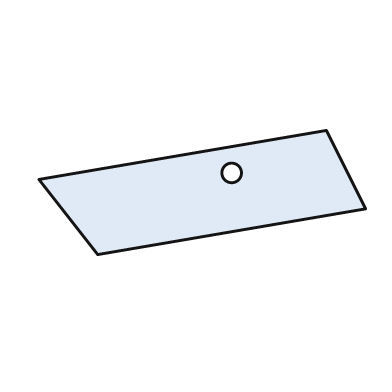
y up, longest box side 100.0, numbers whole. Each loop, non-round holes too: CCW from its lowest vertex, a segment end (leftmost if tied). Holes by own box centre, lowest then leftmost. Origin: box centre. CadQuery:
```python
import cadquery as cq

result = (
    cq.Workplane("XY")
    .moveTo(-32.0, -19.0)
    .lineTo(50.0, -5.0)
    .lineTo(38.0, 19.0)
    .lineTo(-50.0, 4.0)
    .close()
    .moveTo(9.0, 6.0)
    .circle(3.0)
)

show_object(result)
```